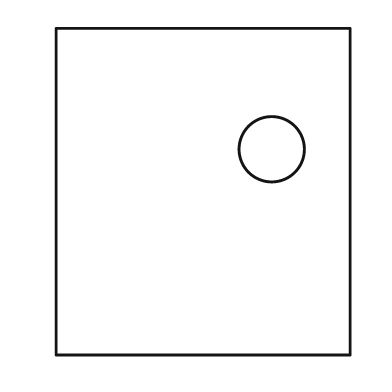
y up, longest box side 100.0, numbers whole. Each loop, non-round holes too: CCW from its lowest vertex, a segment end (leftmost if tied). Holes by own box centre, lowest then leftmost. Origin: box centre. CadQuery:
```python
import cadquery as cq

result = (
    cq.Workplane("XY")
    .moveTo(-45.0, -50.0)
    .lineTo(45.0, -50.0)
    .lineTo(45.0, 50.0)
    .lineTo(-45.0, 50.0)
    .close()
    .moveTo(21.0, 13.0)
    .circle(10.0)
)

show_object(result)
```